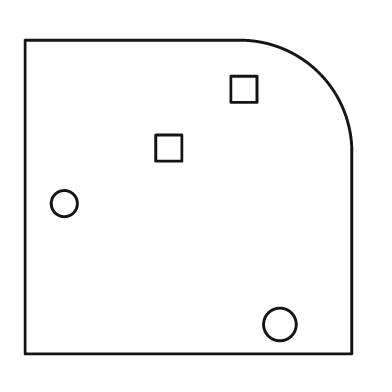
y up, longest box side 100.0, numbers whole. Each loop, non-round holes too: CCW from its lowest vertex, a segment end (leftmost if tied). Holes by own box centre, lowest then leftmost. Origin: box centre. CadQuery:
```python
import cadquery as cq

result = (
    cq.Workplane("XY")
    .moveTo(-50.0, -48.0)
    .lineTo(50.0, -48.0)
    .lineTo(50.0, 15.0)
    .threePointArc((40.0, 38.0), (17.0, 48.0))
    .lineTo(-50.0, 48.0)
    .close()
    .moveTo(28.0, -39.0)
    .circle(5.0)
    .moveTo(-38.0, -2.0)
    .circle(4.0)
    .moveTo(-10.0, 11.0)
    .lineTo(-2.0, 11.0)
    .lineTo(-2.0, 19.0)
    .lineTo(-10.0, 19.0)
    .close()
    .moveTo(13.0, 29.0)
    .lineTo(21.0, 29.0)
    .lineTo(21.0, 37.0)
    .lineTo(13.0, 37.0)
    .close()
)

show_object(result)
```